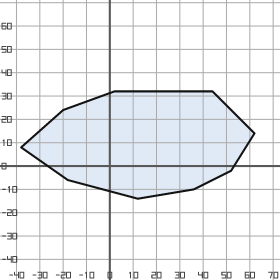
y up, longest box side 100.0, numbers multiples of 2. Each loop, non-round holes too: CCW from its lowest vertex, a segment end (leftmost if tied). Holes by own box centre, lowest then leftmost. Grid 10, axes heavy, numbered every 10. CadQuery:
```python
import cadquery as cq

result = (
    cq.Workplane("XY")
    .moveTo(12.0, -14.0)
    .lineTo(36.0, -10.0)
    .lineTo(52.0, -2.0)
    .lineTo(62.0, 14.0)
    .lineTo(44.0, 32.0)
    .lineTo(2.0, 32.0)
    .lineTo(-20.0, 24.0)
    .lineTo(-38.0, 8.0)
    .lineTo(-18.0, -6.0)
    .close()
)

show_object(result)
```